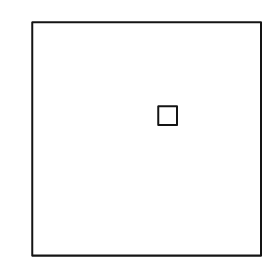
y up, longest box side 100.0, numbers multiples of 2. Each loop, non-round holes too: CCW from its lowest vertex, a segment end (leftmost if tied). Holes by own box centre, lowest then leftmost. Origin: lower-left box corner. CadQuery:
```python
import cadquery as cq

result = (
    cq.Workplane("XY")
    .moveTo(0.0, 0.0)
    .lineTo(98.0, 0.0)
    .lineTo(98.0, 100.0)
    .lineTo(0.0, 100.0)
    .close()
    .moveTo(54.0, 56.0)
    .lineTo(62.0, 56.0)
    .lineTo(62.0, 64.0)
    .lineTo(54.0, 64.0)
    .close()
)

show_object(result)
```